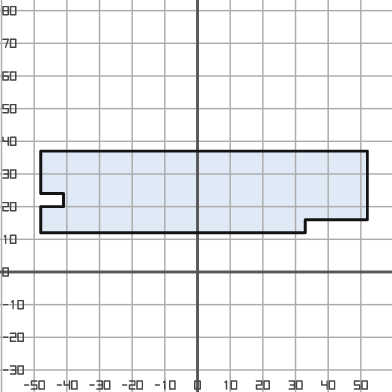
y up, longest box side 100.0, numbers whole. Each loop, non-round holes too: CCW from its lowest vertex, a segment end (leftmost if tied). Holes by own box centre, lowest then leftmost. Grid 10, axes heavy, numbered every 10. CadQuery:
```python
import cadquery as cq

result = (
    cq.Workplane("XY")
    .moveTo(-48.0, 12.0)
    .lineTo(33.0, 12.0)
    .lineTo(33.0, 16.0)
    .lineTo(52.0, 16.0)
    .lineTo(52.0, 37.0)
    .lineTo(-48.0, 37.0)
    .lineTo(-48.0, 24.0)
    .lineTo(-41.0, 24.0)
    .lineTo(-41.0, 20.0)
    .lineTo(-48.0, 20.0)
    .close()
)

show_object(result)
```